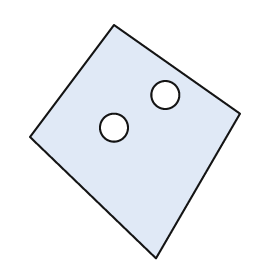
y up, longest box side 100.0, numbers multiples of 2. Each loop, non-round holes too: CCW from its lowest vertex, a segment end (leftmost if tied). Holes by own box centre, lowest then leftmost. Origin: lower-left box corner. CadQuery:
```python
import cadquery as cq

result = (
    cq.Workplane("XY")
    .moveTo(54.0, 0.0)
    .lineTo(90.0, 62.0)
    .lineTo(36.0, 100.0)
    .lineTo(0.0, 52.0)
    .close()
    .moveTo(36.0, 56.0)
    .circle(6.0)
    .moveTo(58.0, 70.0)
    .circle(6.0)
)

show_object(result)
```